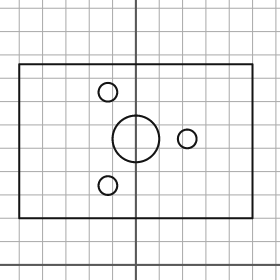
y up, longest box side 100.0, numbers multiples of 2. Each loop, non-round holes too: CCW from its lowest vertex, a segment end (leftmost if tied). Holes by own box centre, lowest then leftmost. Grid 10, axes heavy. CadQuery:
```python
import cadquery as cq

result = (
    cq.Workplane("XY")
    .moveTo(-50.0, 20.0)
    .lineTo(50.0, 20.0)
    .lineTo(50.0, 86.0)
    .lineTo(-50.0, 86.0)
    .close()
    .moveTo(-12.0, 34.0)
    .circle(4.0)
    .moveTo(0.0, 54.0)
    .circle(10.0)
    .moveTo(22.0, 54.0)
    .circle(4.0)
    .moveTo(-12.0, 74.0)
    .circle(4.0)
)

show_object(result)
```